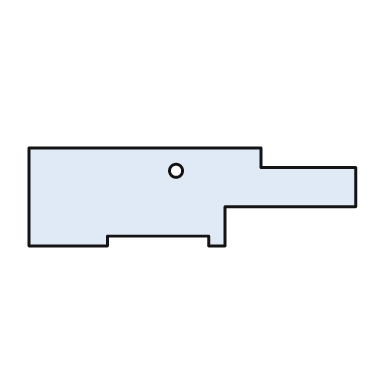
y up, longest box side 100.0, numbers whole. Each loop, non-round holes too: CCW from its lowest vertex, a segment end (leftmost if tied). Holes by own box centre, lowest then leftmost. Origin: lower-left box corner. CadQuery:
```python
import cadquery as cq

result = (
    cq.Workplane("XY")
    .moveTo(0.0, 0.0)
    .lineTo(24.0, 0.0)
    .lineTo(24.0, 3.0)
    .lineTo(55.0, 3.0)
    .lineTo(55.0, 0.0)
    .lineTo(60.0, 0.0)
    .lineTo(60.0, 12.0)
    .lineTo(100.0, 12.0)
    .lineTo(100.0, 24.0)
    .lineTo(71.0, 24.0)
    .lineTo(71.0, 30.0)
    .lineTo(0.0, 30.0)
    .close()
    .moveTo(45.0, 23.0)
    .circle(2.0)
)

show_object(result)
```